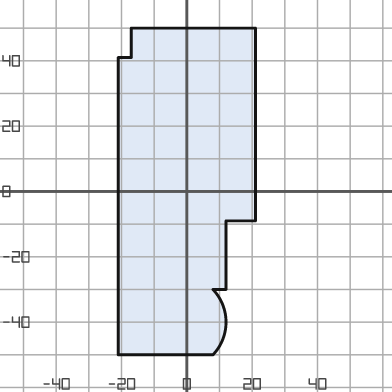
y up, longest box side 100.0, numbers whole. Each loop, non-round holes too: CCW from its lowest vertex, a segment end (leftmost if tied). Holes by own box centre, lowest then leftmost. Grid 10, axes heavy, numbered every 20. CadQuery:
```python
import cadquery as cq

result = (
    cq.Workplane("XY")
    .moveTo(-21.0, -50.0)
    .lineTo(8.0, -50.0)
    .threePointArc((12.0, -40.0), (8.0, -30.0))
    .lineTo(12.0, -30.0)
    .lineTo(12.0, -9.0)
    .lineTo(21.0, -9.0)
    .lineTo(21.0, 50.0)
    .lineTo(-17.0, 50.0)
    .lineTo(-17.0, 41.0)
    .lineTo(-21.0, 41.0)
    .close()
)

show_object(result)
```